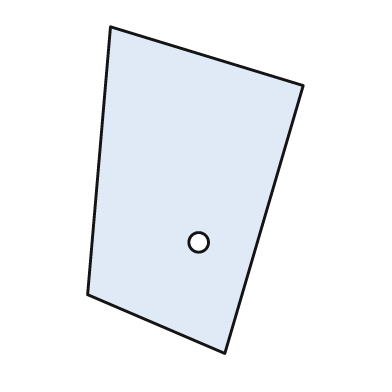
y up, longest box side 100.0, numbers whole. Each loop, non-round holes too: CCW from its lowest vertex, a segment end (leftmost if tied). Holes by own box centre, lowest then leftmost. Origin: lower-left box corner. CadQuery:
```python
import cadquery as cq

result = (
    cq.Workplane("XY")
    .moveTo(42.0, 0.0)
    .lineTo(66.0, 82.0)
    .lineTo(7.0, 100.0)
    .lineTo(0.0, 18.0)
    .close()
    .moveTo(34.0, 34.0)
    .circle(3.0)
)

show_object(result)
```